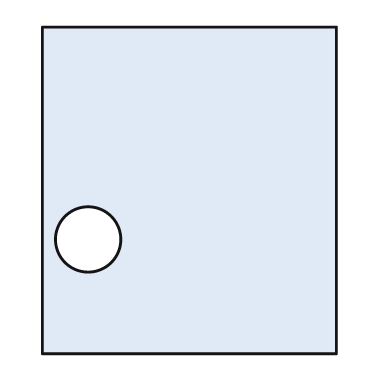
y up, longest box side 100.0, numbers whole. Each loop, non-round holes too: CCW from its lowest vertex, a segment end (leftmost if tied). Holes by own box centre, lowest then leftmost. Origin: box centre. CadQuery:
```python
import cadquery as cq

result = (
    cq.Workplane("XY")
    .moveTo(-45.0, -50.0)
    .lineTo(45.0, -50.0)
    .lineTo(45.0, 50.0)
    .lineTo(-45.0, 50.0)
    .close()
    .moveTo(-31.0, -15.0)
    .circle(10.0)
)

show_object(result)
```